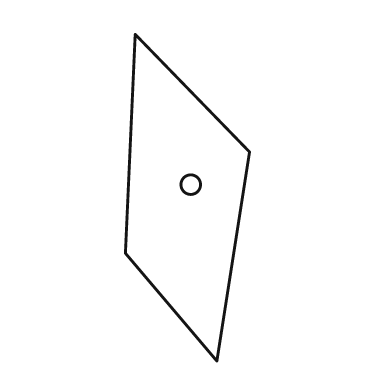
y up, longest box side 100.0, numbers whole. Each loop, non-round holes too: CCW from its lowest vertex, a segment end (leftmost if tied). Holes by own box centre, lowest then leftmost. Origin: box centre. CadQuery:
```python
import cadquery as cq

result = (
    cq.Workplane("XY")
    .moveTo(9.0, -50.0)
    .lineTo(19.0, 14.0)
    .lineTo(-16.0, 50.0)
    .lineTo(-19.0, -17.0)
    .close()
    .moveTo(1.0, 4.0)
    .circle(3.0)
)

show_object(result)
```